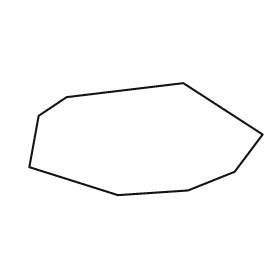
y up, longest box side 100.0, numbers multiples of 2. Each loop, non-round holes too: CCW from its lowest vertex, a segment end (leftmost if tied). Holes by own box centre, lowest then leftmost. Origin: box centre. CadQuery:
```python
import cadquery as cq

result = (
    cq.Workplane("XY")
    .moveTo(-12.0, -24.0)
    .lineTo(18.0, -22.0)
    .lineTo(38.0, -14.0)
    .lineTo(50.0, 2.0)
    .lineTo(16.0, 24.0)
    .lineTo(-34.0, 18.0)
    .lineTo(-46.0, 10.0)
    .lineTo(-50.0, -12.0)
    .close()
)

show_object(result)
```